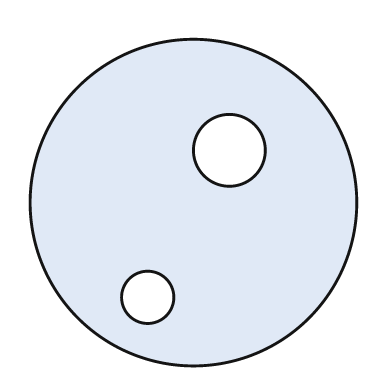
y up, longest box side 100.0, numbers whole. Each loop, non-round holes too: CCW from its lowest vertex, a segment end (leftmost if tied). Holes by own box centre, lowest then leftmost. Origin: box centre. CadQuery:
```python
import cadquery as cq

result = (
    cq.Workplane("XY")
    .moveTo(0.0, 0.0)
    .circle(50.0)
    .moveTo(-14.0, -29.0)
    .circle(8.0)
    .moveTo(11.0, 16.0)
    .circle(11.0)
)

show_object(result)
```